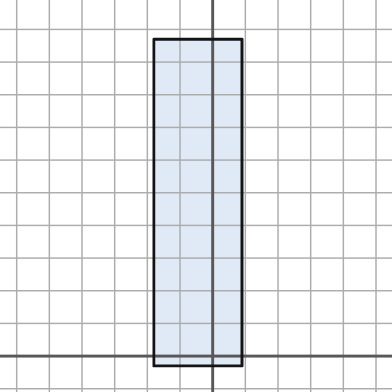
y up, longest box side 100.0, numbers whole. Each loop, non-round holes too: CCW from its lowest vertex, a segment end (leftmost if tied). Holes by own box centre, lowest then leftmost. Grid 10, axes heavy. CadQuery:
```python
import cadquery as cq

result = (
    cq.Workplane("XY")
    .moveTo(-18.0, -3.0)
    .lineTo(9.0, -3.0)
    .lineTo(9.0, 97.0)
    .lineTo(-18.0, 97.0)
    .close()
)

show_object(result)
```